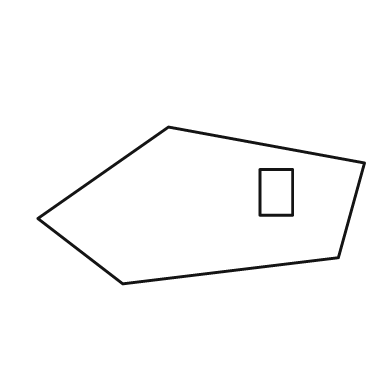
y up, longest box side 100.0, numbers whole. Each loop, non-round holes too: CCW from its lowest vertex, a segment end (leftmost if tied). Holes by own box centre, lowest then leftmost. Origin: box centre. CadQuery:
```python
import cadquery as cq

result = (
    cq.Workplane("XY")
    .moveTo(-24.0, -24.0)
    .lineTo(42.0, -16.0)
    .lineTo(50.0, 13.0)
    .lineTo(-10.0, 24.0)
    .lineTo(-50.0, -4.0)
    .close()
    .moveTo(18.0, -3.0)
    .lineTo(28.0, -3.0)
    .lineTo(28.0, 11.0)
    .lineTo(18.0, 11.0)
    .close()
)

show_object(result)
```